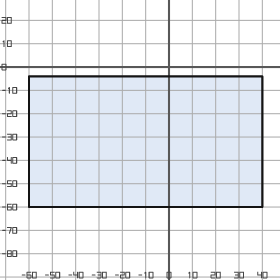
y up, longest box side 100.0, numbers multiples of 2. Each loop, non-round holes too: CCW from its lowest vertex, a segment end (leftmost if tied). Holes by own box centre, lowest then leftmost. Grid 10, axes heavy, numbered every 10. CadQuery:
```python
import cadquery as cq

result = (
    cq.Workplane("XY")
    .moveTo(-60.0, -60.0)
    .lineTo(40.0, -60.0)
    .lineTo(40.0, -4.0)
    .lineTo(-60.0, -4.0)
    .close()
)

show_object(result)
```